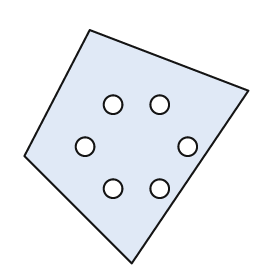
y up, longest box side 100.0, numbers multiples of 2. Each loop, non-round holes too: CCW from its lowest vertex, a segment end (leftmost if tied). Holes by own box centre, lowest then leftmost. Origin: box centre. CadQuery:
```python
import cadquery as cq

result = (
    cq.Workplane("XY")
    .moveTo(-2.0, -50.0)
    .lineTo(48.0, 24.0)
    .lineTo(-20.0, 50.0)
    .lineTo(-48.0, -4.0)
    .close()
    .moveTo(-10.0, -18.0)
    .circle(4.0)
    .moveTo(10.0, -18.0)
    .circle(4.0)
    .moveTo(-22.0, 0.0)
    .circle(4.0)
    .moveTo(22.0, 0.0)
    .circle(4.0)
    .moveTo(-10.0, 18.0)
    .circle(4.0)
    .moveTo(10.0, 18.0)
    .circle(4.0)
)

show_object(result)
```